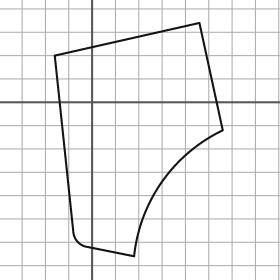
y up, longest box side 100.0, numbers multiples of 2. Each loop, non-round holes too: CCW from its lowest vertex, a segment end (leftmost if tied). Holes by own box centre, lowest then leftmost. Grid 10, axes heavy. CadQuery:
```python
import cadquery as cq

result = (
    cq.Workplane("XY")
    .moveTo(18.0, -66.0)
    .threePointArc((30.0, -34.0), (56.0, -12.0))
    .lineTo(46.0, 34.0)
    .lineTo(-16.0, 20.0)
    .lineTo(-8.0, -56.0)
    .threePointArc((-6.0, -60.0), (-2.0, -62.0))
    .close()
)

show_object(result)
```